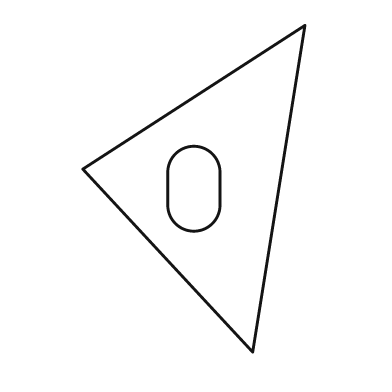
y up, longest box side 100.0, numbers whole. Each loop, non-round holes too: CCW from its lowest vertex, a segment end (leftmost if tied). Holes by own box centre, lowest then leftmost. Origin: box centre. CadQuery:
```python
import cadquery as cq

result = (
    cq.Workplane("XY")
    .moveTo(18.0, -50.0)
    .lineTo(34.0, 50.0)
    .lineTo(-34.0, 6.0)
    .close()
    .moveTo(-8.0, -5.0)
    .threePointArc((0.0, -13.0), (8.0, -5.0))
    .lineTo(8.0, 5.0)
    .threePointArc((0.0, 13.0), (-8.0, 5.0))
    .close()
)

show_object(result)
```